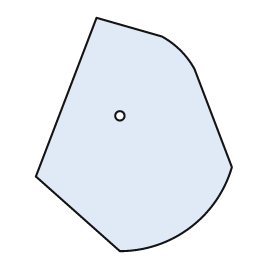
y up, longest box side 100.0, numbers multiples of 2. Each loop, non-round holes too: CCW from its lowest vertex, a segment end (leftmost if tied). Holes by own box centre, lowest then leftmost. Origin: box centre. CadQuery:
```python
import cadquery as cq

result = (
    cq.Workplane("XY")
    .moveTo(-6.0, -50.0)
    .threePointArc((24.0, -40.0), (42.0, -14.0))
    .lineTo(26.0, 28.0)
    .threePointArc((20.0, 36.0), (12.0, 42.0))
    .lineTo(-16.0, 50.0)
    .lineTo(-42.0, -18.0)
    .close()
    .moveTo(-6.0, 8.0)
    .circle(2.0)
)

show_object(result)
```